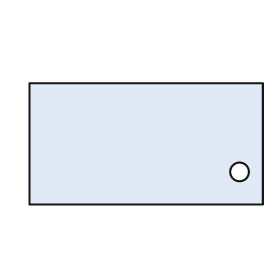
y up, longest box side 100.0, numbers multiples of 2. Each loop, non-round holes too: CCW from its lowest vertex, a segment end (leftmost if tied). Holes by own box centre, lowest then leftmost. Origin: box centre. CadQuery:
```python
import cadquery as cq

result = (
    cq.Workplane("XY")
    .moveTo(-50.0, -26.0)
    .lineTo(50.0, -26.0)
    .lineTo(50.0, 26.0)
    .lineTo(-50.0, 26.0)
    .close()
    .moveTo(40.0, -12.0)
    .circle(4.0)
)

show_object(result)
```